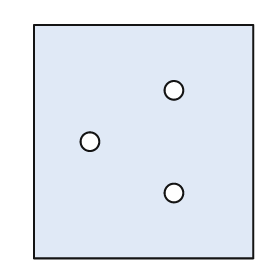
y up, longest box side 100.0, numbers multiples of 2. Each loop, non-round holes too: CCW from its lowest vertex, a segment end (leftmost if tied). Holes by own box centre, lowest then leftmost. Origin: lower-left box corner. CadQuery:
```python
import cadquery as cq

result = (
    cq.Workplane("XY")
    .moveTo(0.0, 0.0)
    .lineTo(94.0, 0.0)
    .lineTo(94.0, 100.0)
    .lineTo(0.0, 100.0)
    .close()
    .moveTo(60.0, 28.0)
    .circle(4.0)
    .moveTo(24.0, 50.0)
    .circle(4.0)
    .moveTo(60.0, 72.0)
    .circle(4.0)
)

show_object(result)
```